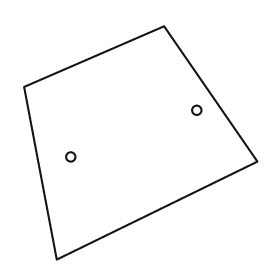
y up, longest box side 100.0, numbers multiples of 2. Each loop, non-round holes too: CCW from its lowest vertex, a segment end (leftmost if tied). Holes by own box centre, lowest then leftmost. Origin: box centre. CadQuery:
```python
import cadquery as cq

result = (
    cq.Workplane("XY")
    .moveTo(-36.0, -50.0)
    .lineTo(50.0, -8.0)
    .lineTo(10.0, 50.0)
    .lineTo(-50.0, 24.0)
    .close()
    .moveTo(-30.0, -6.0)
    .circle(2.0)
    .moveTo(24.0, 14.0)
    .circle(2.0)
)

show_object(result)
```